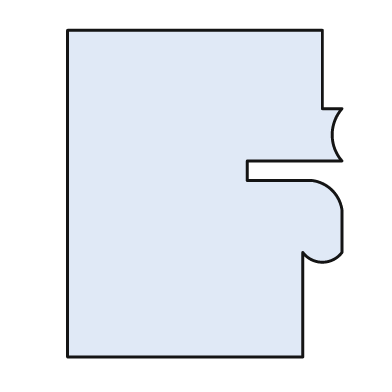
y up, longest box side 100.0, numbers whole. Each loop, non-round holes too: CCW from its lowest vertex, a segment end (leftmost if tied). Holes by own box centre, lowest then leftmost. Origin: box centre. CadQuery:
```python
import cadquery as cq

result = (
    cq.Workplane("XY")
    .moveTo(-42.0, -50.0)
    .lineTo(30.0, -50.0)
    .lineTo(30.0, -18.0)
    .threePointArc((36.0, -21.0), (42.0, -18.0))
    .lineTo(42.0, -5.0)
    .threePointArc((39.0, 1.0), (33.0, 4.0))
    .lineTo(13.0, 4.0)
    .lineTo(13.0, 10.0)
    .lineTo(42.0, 10.0)
    .threePointArc((39.0, 18.0), (42.0, 26.0))
    .lineTo(36.0, 26.0)
    .lineTo(36.0, 50.0)
    .lineTo(-42.0, 50.0)
    .close()
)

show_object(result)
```